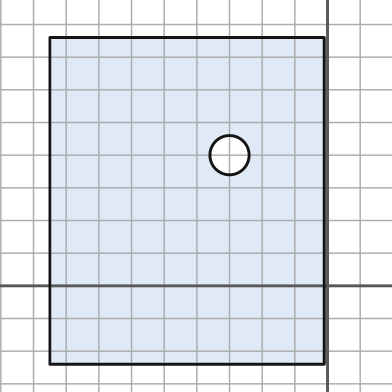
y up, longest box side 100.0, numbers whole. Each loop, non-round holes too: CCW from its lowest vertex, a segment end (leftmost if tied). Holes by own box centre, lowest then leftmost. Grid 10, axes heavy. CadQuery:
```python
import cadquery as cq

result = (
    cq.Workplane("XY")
    .moveTo(-85.0, -24.0)
    .lineTo(-1.0, -24.0)
    .lineTo(-1.0, 76.0)
    .lineTo(-85.0, 76.0)
    .close()
    .moveTo(-30.0, 40.0)
    .circle(6.0)
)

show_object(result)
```